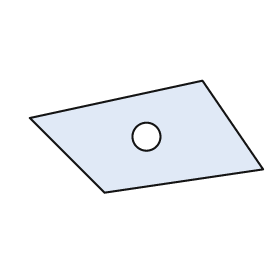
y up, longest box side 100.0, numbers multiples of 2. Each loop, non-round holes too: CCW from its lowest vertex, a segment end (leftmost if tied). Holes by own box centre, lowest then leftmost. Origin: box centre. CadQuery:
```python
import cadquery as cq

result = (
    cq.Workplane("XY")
    .moveTo(-18.0, -24.0)
    .lineTo(50.0, -14.0)
    .lineTo(24.0, 24.0)
    .lineTo(-50.0, 8.0)
    .close()
    .moveTo(0.0, 0.0)
    .circle(6.0)
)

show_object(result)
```